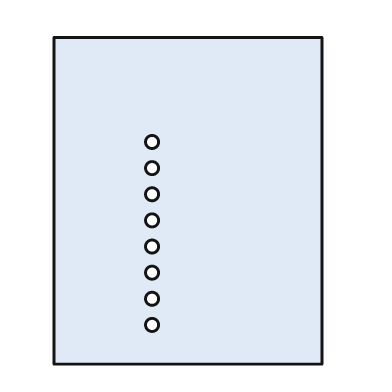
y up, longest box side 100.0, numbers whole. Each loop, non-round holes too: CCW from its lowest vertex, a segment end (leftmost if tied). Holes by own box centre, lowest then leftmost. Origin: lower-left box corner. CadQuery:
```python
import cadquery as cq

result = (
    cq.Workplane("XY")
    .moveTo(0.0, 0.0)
    .lineTo(82.0, 0.0)
    .lineTo(82.0, 100.0)
    .lineTo(0.0, 100.0)
    .close()
    .moveTo(30.0, 12.0)
    .circle(2.0)
    .moveTo(30.0, 20.0)
    .circle(2.0)
    .moveTo(30.0, 28.0)
    .circle(2.0)
    .moveTo(30.0, 36.0)
    .circle(2.0)
    .moveTo(30.0, 44.0)
    .circle(2.0)
    .moveTo(30.0, 52.0)
    .circle(2.0)
    .moveTo(30.0, 60.0)
    .circle(2.0)
    .moveTo(30.0, 68.0)
    .circle(2.0)
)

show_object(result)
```